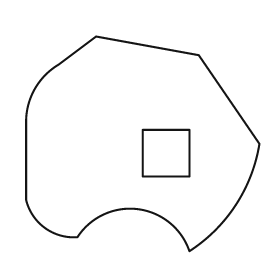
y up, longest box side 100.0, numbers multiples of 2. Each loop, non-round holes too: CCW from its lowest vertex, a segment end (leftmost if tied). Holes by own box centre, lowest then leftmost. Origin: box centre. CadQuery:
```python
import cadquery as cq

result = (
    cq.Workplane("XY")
    .moveTo(20.0, -46.0)
    .threePointArc((40.0, -26.0), (50.0, 0.0))
    .lineTo(24.0, 38.0)
    .lineTo(-20.0, 46.0)
    .lineTo(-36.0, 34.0)
    .threePointArc((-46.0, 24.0), (-50.0, 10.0))
    .lineTo(-50.0, -24.0)
    .threePointArc((-42.0, -36.0), (-28.0, -40.0))
    .threePointArc((-2.0, -28.0), (20.0, -46.0))
    .close()
    .moveTo(0.0, -14.0)
    .lineTo(20.0, -14.0)
    .lineTo(20.0, 6.0)
    .lineTo(0.0, 6.0)
    .close()
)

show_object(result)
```